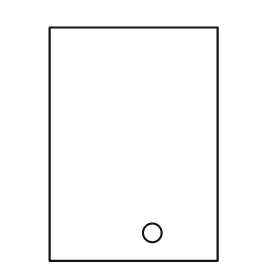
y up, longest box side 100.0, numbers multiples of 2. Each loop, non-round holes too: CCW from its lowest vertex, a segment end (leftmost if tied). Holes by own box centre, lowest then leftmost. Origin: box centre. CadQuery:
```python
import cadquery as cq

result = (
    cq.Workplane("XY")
    .moveTo(-36.0, -50.0)
    .lineTo(36.0, -50.0)
    .lineTo(36.0, 50.0)
    .lineTo(-36.0, 50.0)
    .close()
    .moveTo(8.0, -38.0)
    .circle(4.0)
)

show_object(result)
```